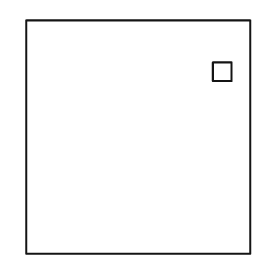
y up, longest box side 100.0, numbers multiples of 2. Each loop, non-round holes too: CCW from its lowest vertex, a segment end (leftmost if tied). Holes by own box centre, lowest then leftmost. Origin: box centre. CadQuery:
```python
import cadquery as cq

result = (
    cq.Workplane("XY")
    .moveTo(-48.0, -50.0)
    .lineTo(48.0, -50.0)
    .lineTo(48.0, 50.0)
    .lineTo(-48.0, 50.0)
    .close()
    .moveTo(32.0, 24.0)
    .lineTo(40.0, 24.0)
    .lineTo(40.0, 32.0)
    .lineTo(32.0, 32.0)
    .close()
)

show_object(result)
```